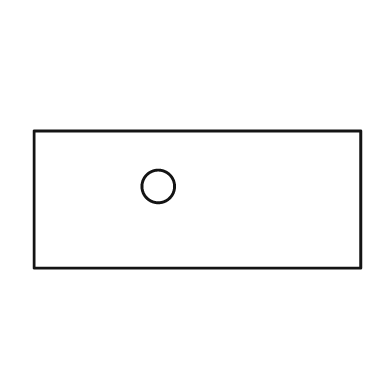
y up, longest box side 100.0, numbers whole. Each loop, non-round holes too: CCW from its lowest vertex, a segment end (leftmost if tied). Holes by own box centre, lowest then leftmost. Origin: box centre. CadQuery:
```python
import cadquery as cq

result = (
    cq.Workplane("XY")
    .moveTo(-50.0, -21.0)
    .lineTo(50.0, -21.0)
    .lineTo(50.0, 21.0)
    .lineTo(-50.0, 21.0)
    .close()
    .moveTo(-12.0, 4.0)
    .circle(5.0)
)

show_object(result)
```